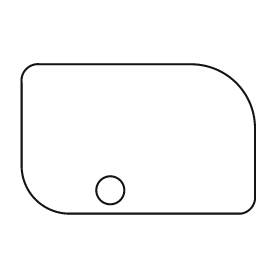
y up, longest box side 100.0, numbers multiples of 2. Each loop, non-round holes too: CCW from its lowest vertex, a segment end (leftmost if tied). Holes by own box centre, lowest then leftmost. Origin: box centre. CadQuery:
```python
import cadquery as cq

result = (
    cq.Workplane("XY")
    .moveTo(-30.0, -32.0)
    .lineTo(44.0, -32.0)
    .threePointArc((48.0, -30.0), (50.0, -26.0))
    .lineTo(50.0, 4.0)
    .threePointArc((42.0, 24.0), (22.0, 32.0))
    .lineTo(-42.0, 32.0)
    .threePointArc((-48.0, 30.0), (-50.0, 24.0))
    .lineTo(-50.0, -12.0)
    .threePointArc((-44.0, -26.0), (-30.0, -32.0))
    .close()
    .moveTo(-12.0, -22.0)
    .circle(6.0)
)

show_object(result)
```